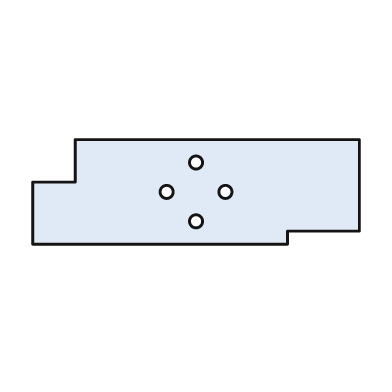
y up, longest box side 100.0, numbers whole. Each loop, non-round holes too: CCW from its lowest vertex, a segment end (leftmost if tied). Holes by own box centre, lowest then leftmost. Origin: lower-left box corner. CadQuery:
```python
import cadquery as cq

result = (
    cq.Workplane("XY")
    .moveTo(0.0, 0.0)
    .lineTo(78.0, 0.0)
    .lineTo(78.0, 4.0)
    .lineTo(100.0, 4.0)
    .lineTo(100.0, 32.0)
    .lineTo(13.0, 32.0)
    .lineTo(13.0, 19.0)
    .lineTo(0.0, 19.0)
    .close()
    .moveTo(50.0, 7.0)
    .circle(2.0)
    .moveTo(41.0, 16.0)
    .circle(2.0)
    .moveTo(59.0, 16.0)
    .circle(2.0)
    .moveTo(50.0, 25.0)
    .circle(2.0)
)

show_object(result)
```